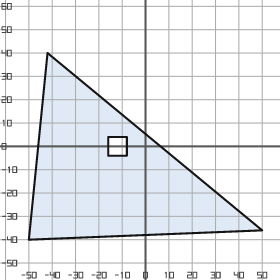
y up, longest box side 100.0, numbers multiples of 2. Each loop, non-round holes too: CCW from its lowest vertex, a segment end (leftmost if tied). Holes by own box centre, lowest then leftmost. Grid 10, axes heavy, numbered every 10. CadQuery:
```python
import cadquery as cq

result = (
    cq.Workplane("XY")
    .moveTo(-50.0, -40.0)
    .lineTo(50.0, -36.0)
    .lineTo(-42.0, 40.0)
    .close()
    .moveTo(-16.0, -4.0)
    .lineTo(-8.0, -4.0)
    .lineTo(-8.0, 4.0)
    .lineTo(-16.0, 4.0)
    .close()
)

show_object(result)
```